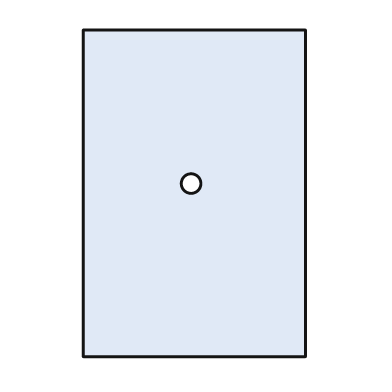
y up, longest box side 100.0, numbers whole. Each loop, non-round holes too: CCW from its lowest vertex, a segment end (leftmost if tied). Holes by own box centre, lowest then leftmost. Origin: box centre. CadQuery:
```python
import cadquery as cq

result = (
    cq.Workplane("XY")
    .moveTo(-34.0, -50.0)
    .lineTo(34.0, -50.0)
    .lineTo(34.0, 50.0)
    .lineTo(-34.0, 50.0)
    .close()
    .moveTo(-1.0, 3.0)
    .circle(3.0)
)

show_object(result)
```